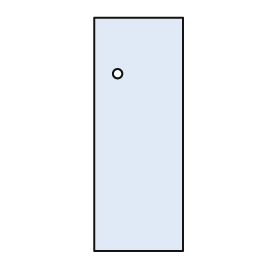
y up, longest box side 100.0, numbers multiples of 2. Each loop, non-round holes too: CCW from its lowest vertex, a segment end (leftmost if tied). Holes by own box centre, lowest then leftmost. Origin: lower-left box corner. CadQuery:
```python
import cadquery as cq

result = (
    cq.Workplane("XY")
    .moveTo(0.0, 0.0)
    .lineTo(38.0, 0.0)
    .lineTo(38.0, 100.0)
    .lineTo(0.0, 100.0)
    .close()
    .moveTo(10.0, 76.0)
    .circle(2.0)
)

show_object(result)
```